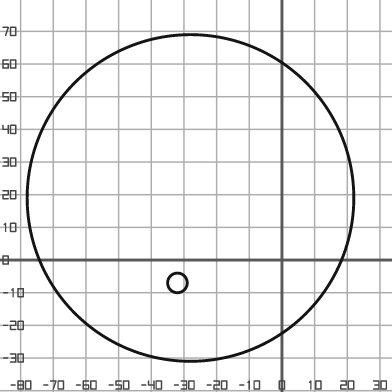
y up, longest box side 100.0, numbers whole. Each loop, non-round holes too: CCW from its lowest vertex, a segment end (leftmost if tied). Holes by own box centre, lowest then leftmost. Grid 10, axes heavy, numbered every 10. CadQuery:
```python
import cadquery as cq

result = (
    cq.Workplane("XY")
    .moveTo(-28.0, 19.0)
    .circle(50.0)
    .moveTo(-32.0, -7.0)
    .circle(3.0)
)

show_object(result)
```